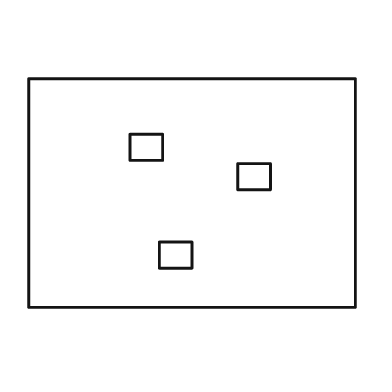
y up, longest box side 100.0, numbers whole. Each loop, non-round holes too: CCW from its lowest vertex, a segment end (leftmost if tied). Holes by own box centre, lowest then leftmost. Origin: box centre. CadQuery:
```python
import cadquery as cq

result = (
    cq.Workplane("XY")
    .moveTo(-50.0, -35.0)
    .lineTo(50.0, -35.0)
    .lineTo(50.0, 35.0)
    .lineTo(-50.0, 35.0)
    .close()
    .moveTo(-10.0, -23.0)
    .lineTo(0.0, -23.0)
    .lineTo(0.0, -15.0)
    .lineTo(-10.0, -15.0)
    .close()
    .moveTo(14.0, 1.0)
    .lineTo(24.0, 1.0)
    .lineTo(24.0, 9.0)
    .lineTo(14.0, 9.0)
    .close()
    .moveTo(-19.0, 10.0)
    .lineTo(-9.0, 10.0)
    .lineTo(-9.0, 18.0)
    .lineTo(-19.0, 18.0)
    .close()
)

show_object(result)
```